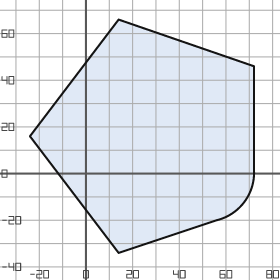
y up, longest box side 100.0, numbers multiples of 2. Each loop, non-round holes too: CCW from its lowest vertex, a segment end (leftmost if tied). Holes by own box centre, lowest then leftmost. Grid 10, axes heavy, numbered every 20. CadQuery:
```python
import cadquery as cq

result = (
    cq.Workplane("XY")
    .moveTo(14.0, -34.0)
    .lineTo(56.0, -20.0)
    .threePointArc((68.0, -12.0), (72.0, 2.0))
    .lineTo(72.0, 46.0)
    .lineTo(14.0, 66.0)
    .lineTo(-24.0, 16.0)
    .close()
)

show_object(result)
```